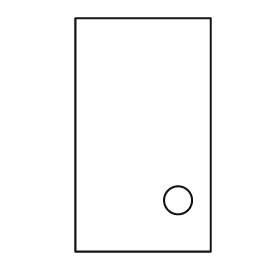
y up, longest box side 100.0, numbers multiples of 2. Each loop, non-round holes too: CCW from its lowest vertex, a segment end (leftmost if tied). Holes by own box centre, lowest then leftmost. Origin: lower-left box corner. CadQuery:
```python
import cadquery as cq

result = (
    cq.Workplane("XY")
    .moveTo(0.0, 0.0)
    .lineTo(58.0, 0.0)
    .lineTo(58.0, 100.0)
    .lineTo(0.0, 100.0)
    .close()
    .moveTo(44.0, 22.0)
    .circle(6.0)
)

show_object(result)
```